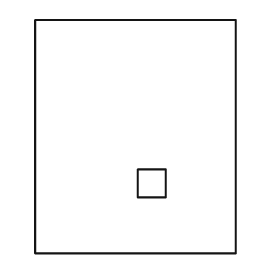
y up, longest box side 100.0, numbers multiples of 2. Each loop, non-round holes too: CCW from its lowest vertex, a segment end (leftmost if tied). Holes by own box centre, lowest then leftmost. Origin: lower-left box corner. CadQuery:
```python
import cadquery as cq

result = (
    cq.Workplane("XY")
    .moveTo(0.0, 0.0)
    .lineTo(86.0, 0.0)
    .lineTo(86.0, 100.0)
    .lineTo(0.0, 100.0)
    .close()
    .moveTo(44.0, 24.0)
    .lineTo(56.0, 24.0)
    .lineTo(56.0, 36.0)
    .lineTo(44.0, 36.0)
    .close()
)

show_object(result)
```